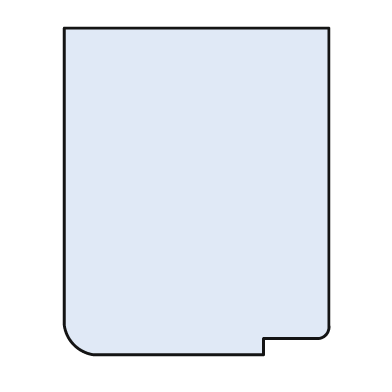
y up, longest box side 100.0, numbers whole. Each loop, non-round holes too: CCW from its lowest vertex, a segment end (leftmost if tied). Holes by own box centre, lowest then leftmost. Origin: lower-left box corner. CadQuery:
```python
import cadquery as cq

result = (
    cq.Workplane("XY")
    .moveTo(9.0, 0.0)
    .lineTo(61.0, 0.0)
    .lineTo(61.0, 5.0)
    .lineTo(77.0, 5.0)
    .threePointArc((80.0, 6.0), (81.0, 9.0))
    .lineTo(81.0, 100.0)
    .lineTo(0.0, 100.0)
    .lineTo(0.0, 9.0)
    .threePointArc((3.0, 3.0), (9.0, 0.0))
    .close()
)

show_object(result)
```